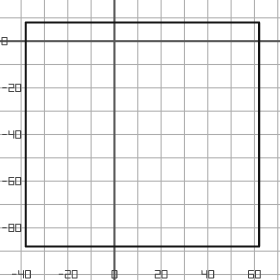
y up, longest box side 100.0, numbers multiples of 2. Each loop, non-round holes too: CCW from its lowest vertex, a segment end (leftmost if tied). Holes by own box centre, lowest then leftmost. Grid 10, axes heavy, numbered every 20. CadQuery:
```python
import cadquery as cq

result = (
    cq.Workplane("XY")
    .moveTo(-38.0, -88.0)
    .lineTo(62.0, -88.0)
    .lineTo(62.0, 8.0)
    .lineTo(-38.0, 8.0)
    .close()
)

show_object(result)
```